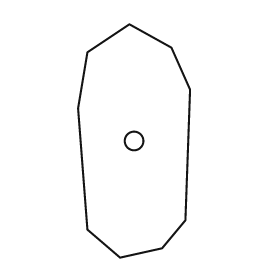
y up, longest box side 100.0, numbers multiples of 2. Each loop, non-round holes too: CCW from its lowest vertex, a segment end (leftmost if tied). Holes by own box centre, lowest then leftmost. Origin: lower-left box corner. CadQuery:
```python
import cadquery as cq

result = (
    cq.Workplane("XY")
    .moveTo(18.0, 0.0)
    .lineTo(36.0, 4.0)
    .lineTo(46.0, 16.0)
    .lineTo(48.0, 72.0)
    .lineTo(40.0, 90.0)
    .lineTo(22.0, 100.0)
    .lineTo(4.0, 88.0)
    .lineTo(0.0, 64.0)
    .lineTo(4.0, 12.0)
    .close()
    .moveTo(24.0, 50.0)
    .circle(4.0)
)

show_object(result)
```